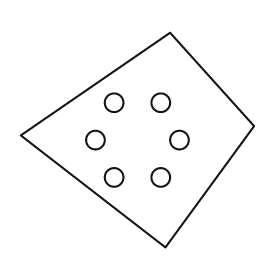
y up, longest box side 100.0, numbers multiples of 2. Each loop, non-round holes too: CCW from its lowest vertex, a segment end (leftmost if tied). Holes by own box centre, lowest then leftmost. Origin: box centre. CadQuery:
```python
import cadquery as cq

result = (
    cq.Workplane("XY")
    .moveTo(12.0, -46.0)
    .lineTo(50.0, 6.0)
    .lineTo(14.0, 46.0)
    .lineTo(-50.0, 2.0)
    .close()
    .moveTo(-10.0, -16.0)
    .circle(4.0)
    .moveTo(10.0, -16.0)
    .circle(4.0)
    .moveTo(-18.0, 0.0)
    .circle(4.0)
    .moveTo(18.0, 0.0)
    .circle(4.0)
    .moveTo(-10.0, 16.0)
    .circle(4.0)
    .moveTo(10.0, 16.0)
    .circle(4.0)
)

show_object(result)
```